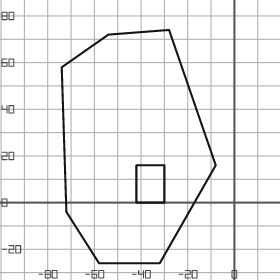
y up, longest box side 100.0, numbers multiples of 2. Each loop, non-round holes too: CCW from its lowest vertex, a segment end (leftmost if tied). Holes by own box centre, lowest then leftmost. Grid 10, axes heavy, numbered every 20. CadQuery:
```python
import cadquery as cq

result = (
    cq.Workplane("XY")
    .moveTo(-58.0, -26.0)
    .lineTo(-32.0, -26.0)
    .lineTo(-8.0, 16.0)
    .lineTo(-28.0, 74.0)
    .lineTo(-54.0, 72.0)
    .lineTo(-74.0, 58.0)
    .lineTo(-72.0, -4.0)
    .close()
    .moveTo(-42.0, 0.0)
    .lineTo(-30.0, 0.0)
    .lineTo(-30.0, 16.0)
    .lineTo(-42.0, 16.0)
    .close()
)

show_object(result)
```